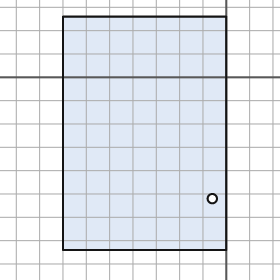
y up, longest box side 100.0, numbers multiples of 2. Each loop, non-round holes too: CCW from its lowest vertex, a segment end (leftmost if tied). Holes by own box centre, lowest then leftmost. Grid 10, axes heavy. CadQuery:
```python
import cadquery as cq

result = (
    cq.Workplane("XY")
    .moveTo(-70.0, -74.0)
    .lineTo(0.0, -74.0)
    .lineTo(0.0, 26.0)
    .lineTo(-70.0, 26.0)
    .close()
    .moveTo(-6.0, -52.0)
    .circle(2.0)
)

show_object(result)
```